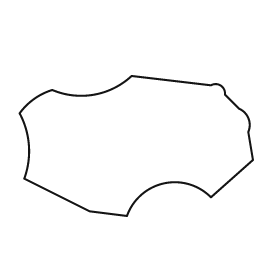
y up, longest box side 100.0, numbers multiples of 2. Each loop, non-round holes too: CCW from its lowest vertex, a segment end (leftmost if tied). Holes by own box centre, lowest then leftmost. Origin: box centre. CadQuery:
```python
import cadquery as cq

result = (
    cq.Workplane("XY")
    .moveTo(-4.0, -30.0)
    .threePointArc((12.0, -16.0), (32.0, -22.0))
    .lineTo(50.0, -6.0)
    .lineTo(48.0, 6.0)
    .threePointArc((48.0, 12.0), (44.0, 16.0))
    .lineTo(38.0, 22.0)
    .threePointArc((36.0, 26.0), (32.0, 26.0))
    .lineTo(-2.0, 30.0)
    .threePointArc((-18.0, 22.0), (-36.0, 24.0))
    .threePointArc((-44.0, 20.0), (-50.0, 14.0))
    .threePointArc((-46.0, 0.0), (-48.0, -14.0))
    .lineTo(-20.0, -28.0)
    .close()
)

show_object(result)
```